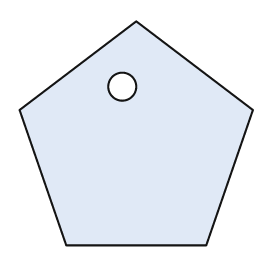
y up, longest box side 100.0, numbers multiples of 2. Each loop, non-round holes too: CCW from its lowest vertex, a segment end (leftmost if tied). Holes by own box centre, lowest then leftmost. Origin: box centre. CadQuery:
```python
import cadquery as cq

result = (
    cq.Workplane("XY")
    .moveTo(-30.0, -48.0)
    .lineTo(30.0, -48.0)
    .lineTo(50.0, 10.0)
    .lineTo(0.0, 48.0)
    .lineTo(-50.0, 10.0)
    .close()
    .moveTo(-6.0, 20.0)
    .circle(6.0)
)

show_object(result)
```